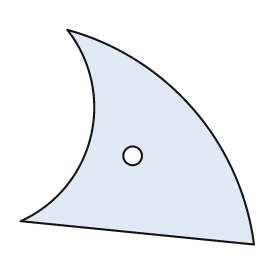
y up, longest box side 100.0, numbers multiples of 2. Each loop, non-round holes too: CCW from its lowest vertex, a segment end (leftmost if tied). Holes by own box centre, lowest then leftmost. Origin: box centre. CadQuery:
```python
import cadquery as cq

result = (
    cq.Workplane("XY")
    .moveTo(50.0, -46.0)
    .threePointArc((24.0, 12.0), (-30.0, 46.0))
    .threePointArc((-20.0, 0.0), (-50.0, -36.0))
    .close()
    .moveTo(-2.0, -8.0)
    .circle(4.0)
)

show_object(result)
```